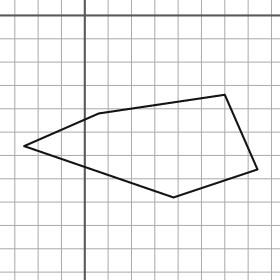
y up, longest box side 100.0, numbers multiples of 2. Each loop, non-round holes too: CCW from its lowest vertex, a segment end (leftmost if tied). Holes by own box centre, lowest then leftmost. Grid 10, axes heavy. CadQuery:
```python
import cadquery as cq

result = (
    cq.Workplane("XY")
    .moveTo(38.0, -78.0)
    .lineTo(74.0, -66.0)
    .lineTo(60.0, -34.0)
    .lineTo(6.0, -42.0)
    .lineTo(-26.0, -56.0)
    .close()
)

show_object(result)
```